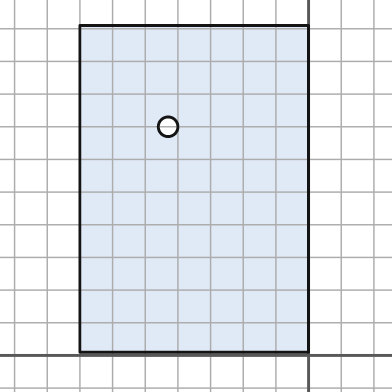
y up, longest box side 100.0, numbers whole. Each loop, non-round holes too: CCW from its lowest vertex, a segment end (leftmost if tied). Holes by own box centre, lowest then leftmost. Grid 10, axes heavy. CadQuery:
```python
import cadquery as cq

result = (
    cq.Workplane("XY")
    .moveTo(-70.0, 1.0)
    .lineTo(0.0, 1.0)
    .lineTo(0.0, 101.0)
    .lineTo(-70.0, 101.0)
    .close()
    .moveTo(-43.0, 70.0)
    .circle(3.0)
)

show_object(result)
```